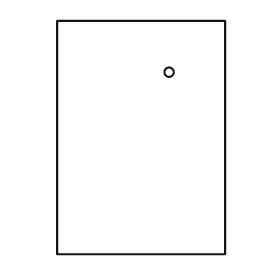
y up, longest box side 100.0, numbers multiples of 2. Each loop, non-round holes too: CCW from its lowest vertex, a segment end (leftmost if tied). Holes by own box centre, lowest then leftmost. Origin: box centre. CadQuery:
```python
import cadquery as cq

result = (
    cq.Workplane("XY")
    .moveTo(-36.0, -50.0)
    .lineTo(36.0, -50.0)
    .lineTo(36.0, 50.0)
    .lineTo(-36.0, 50.0)
    .close()
    .moveTo(12.0, 28.0)
    .circle(2.0)
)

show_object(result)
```